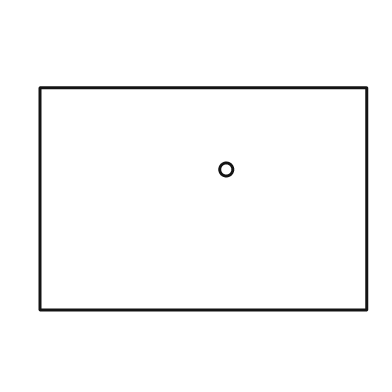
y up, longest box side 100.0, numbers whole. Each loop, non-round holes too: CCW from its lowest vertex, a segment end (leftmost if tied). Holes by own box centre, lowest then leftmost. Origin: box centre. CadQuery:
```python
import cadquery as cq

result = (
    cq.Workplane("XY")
    .moveTo(-50.0, -34.0)
    .lineTo(50.0, -34.0)
    .lineTo(50.0, 34.0)
    .lineTo(-50.0, 34.0)
    .close()
    .moveTo(7.0, 9.0)
    .circle(2.0)
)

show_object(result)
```